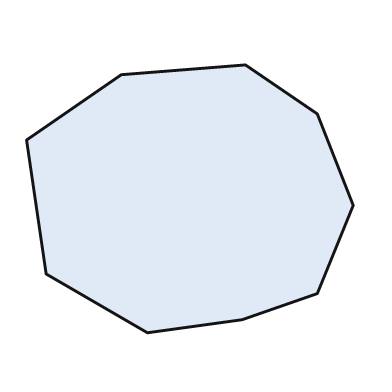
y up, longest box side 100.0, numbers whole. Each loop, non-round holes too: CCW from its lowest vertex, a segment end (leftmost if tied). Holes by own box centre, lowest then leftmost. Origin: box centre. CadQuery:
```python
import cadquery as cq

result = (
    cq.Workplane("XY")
    .moveTo(-13.0, -41.0)
    .lineTo(16.0, -37.0)
    .lineTo(39.0, -29.0)
    .lineTo(50.0, -2.0)
    .lineTo(39.0, 26.0)
    .lineTo(17.0, 41.0)
    .lineTo(-21.0, 38.0)
    .lineTo(-50.0, 18.0)
    .lineTo(-44.0, -23.0)
    .close()
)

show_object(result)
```